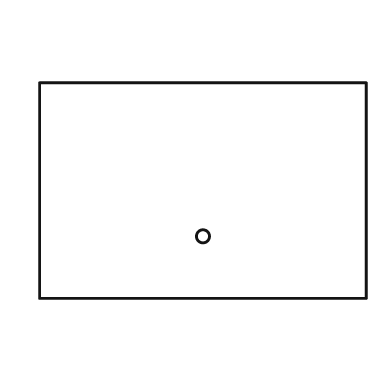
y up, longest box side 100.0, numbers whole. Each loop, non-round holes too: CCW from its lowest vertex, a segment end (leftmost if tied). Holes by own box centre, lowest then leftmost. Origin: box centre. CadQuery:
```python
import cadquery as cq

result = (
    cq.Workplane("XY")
    .moveTo(-50.0, -33.0)
    .lineTo(50.0, -33.0)
    .lineTo(50.0, 33.0)
    .lineTo(-50.0, 33.0)
    .close()
    .moveTo(0.0, -14.0)
    .circle(2.0)
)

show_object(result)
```